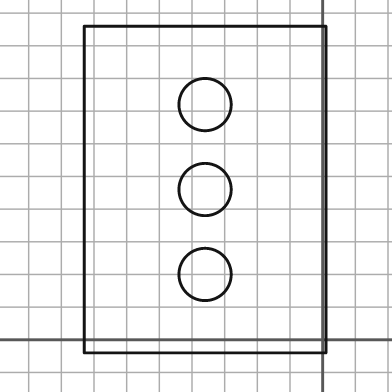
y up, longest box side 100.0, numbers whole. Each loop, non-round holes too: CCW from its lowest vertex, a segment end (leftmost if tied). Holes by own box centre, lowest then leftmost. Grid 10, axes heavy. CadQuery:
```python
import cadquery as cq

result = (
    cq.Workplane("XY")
    .moveTo(-73.0, -4.0)
    .lineTo(1.0, -4.0)
    .lineTo(1.0, 96.0)
    .lineTo(-73.0, 96.0)
    .close()
    .moveTo(-36.0, 20.0)
    .circle(8.0)
    .moveTo(-36.0, 46.0)
    .circle(8.0)
    .moveTo(-36.0, 72.0)
    .circle(8.0)
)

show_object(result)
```